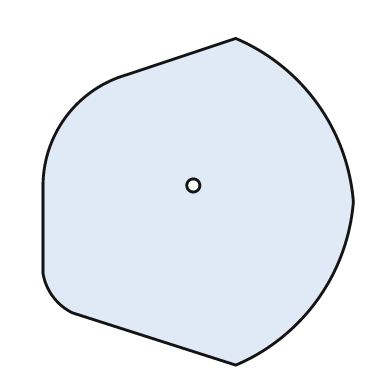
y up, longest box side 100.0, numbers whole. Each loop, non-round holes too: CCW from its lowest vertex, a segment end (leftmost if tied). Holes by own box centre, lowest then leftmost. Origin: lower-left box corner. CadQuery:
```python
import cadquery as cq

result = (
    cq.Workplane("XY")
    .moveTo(59.0, 0.0)
    .threePointArc((84.0, 20.0), (95.0, 50.0))
    .threePointArc((84.0, 80.0), (59.0, 100.0))
    .lineTo(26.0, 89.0)
    .threePointArc((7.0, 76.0), (0.0, 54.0))
    .lineTo(0.0, 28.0)
    .threePointArc((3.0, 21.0), (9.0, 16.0))
    .close()
    .moveTo(46.0, 55.0)
    .circle(2.0)
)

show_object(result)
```